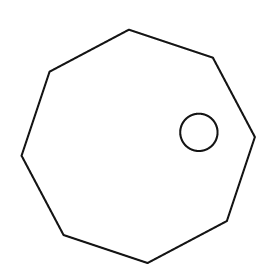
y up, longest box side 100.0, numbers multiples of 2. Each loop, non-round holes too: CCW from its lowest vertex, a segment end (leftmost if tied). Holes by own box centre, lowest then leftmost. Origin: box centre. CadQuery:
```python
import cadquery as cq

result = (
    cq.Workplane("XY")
    .moveTo(4.0, -50.0)
    .lineTo(38.0, -32.0)
    .lineTo(50.0, 4.0)
    .lineTo(32.0, 38.0)
    .lineTo(-4.0, 50.0)
    .lineTo(-38.0, 32.0)
    .lineTo(-50.0, -4.0)
    .lineTo(-32.0, -38.0)
    .close()
    .moveTo(26.0, 6.0)
    .circle(8.0)
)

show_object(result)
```